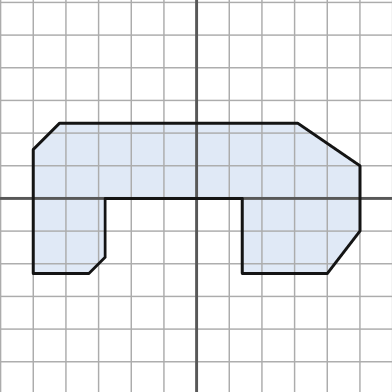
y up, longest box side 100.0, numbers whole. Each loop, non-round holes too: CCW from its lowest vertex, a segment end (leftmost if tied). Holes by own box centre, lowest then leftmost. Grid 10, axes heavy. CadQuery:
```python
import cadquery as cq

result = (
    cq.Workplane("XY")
    .moveTo(-50.0, -23.0)
    .lineTo(-33.0, -23.0)
    .lineTo(-28.0, -18.0)
    .lineTo(-28.0, 0.0)
    .lineTo(14.0, 0.0)
    .lineTo(14.0, -23.0)
    .lineTo(40.0, -23.0)
    .lineTo(50.0, -10.0)
    .lineTo(50.0, 10.0)
    .lineTo(31.0, 23.0)
    .lineTo(-42.0, 23.0)
    .lineTo(-50.0, 15.0)
    .close()
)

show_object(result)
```